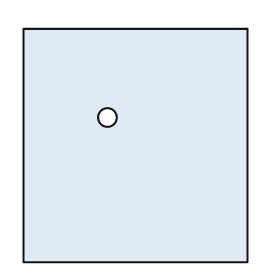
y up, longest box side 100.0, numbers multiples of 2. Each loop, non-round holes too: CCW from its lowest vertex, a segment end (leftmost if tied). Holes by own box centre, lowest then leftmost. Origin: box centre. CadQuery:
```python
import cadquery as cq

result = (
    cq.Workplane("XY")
    .moveTo(-48.0, -50.0)
    .lineTo(48.0, -50.0)
    .lineTo(48.0, 50.0)
    .lineTo(-48.0, 50.0)
    .close()
    .moveTo(-12.0, 12.0)
    .circle(4.0)
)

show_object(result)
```